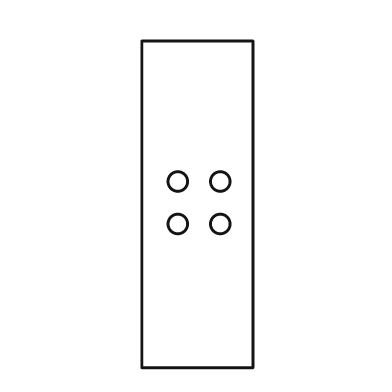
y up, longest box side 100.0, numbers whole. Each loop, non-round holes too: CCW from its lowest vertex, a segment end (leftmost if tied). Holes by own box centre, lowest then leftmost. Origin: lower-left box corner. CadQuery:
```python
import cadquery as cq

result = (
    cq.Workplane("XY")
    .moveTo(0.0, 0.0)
    .lineTo(34.0, 0.0)
    .lineTo(34.0, 100.0)
    .lineTo(0.0, 100.0)
    .close()
    .moveTo(11.0, 44.0)
    .circle(3.0)
    .moveTo(24.0, 44.0)
    .circle(3.0)
    .moveTo(11.0, 57.0)
    .circle(3.0)
    .moveTo(24.0, 57.0)
    .circle(3.0)
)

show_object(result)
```